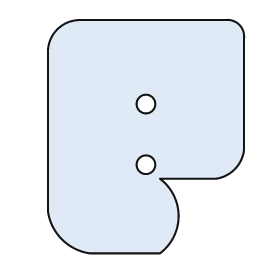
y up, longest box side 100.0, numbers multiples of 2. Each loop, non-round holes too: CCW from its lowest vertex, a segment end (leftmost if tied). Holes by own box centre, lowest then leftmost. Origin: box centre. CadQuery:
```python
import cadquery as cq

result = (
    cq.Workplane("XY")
    .moveTo(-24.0, -50.0)
    .lineTo(6.0, -50.0)
    .threePointArc((14.0, -34.0), (6.0, -18.0))
    .lineTo(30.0, -18.0)
    .threePointArc((38.0, -14.0), (42.0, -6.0))
    .lineTo(42.0, 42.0)
    .threePointArc((40.0, 48.0), (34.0, 50.0))
    .lineTo(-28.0, 50.0)
    .threePointArc((-38.0, 46.0), (-42.0, 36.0))
    .lineTo(-42.0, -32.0)
    .threePointArc((-36.0, -44.0), (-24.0, -50.0))
    .close()
    .moveTo(0.0, -12.0)
    .circle(4.0)
    .moveTo(0.0, 14.0)
    .circle(4.0)
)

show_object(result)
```